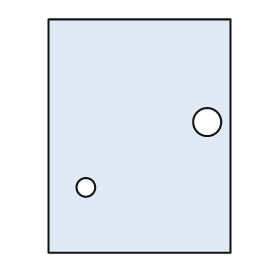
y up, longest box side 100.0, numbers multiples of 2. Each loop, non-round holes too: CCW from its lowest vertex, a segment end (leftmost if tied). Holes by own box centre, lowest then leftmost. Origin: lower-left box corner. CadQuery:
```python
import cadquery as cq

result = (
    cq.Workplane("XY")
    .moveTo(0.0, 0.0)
    .lineTo(78.0, 0.0)
    .lineTo(78.0, 100.0)
    .lineTo(0.0, 100.0)
    .close()
    .moveTo(16.0, 28.0)
    .circle(4.0)
    .moveTo(68.0, 56.0)
    .circle(6.0)
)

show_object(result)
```